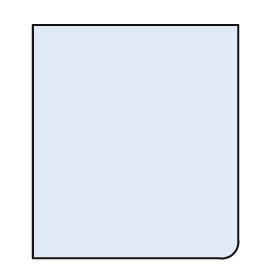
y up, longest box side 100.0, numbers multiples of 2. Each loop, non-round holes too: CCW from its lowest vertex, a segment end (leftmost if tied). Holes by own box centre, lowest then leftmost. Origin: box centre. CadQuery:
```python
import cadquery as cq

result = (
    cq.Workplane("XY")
    .moveTo(-44.0, -50.0)
    .lineTo(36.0, -50.0)
    .threePointArc((42.0, -48.0), (44.0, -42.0))
    .lineTo(44.0, 50.0)
    .lineTo(-44.0, 50.0)
    .close()
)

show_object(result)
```